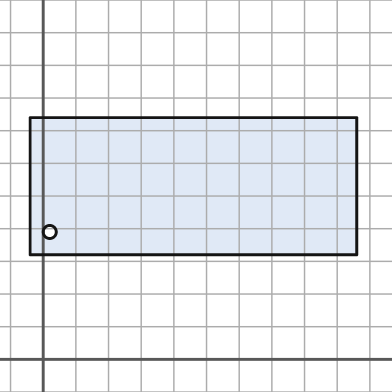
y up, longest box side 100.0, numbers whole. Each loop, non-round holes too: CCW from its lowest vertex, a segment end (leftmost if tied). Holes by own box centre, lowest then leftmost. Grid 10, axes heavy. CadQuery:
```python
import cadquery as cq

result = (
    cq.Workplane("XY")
    .moveTo(-4.0, 32.0)
    .lineTo(96.0, 32.0)
    .lineTo(96.0, 74.0)
    .lineTo(-4.0, 74.0)
    .close()
    .moveTo(2.0, 39.0)
    .circle(2.0)
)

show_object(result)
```